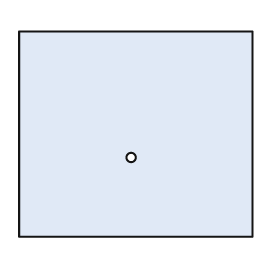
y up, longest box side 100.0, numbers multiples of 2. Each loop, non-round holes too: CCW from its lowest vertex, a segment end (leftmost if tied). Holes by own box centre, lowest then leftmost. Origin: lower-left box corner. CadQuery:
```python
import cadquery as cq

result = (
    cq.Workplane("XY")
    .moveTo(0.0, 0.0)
    .lineTo(100.0, 0.0)
    .lineTo(100.0, 88.0)
    .lineTo(0.0, 88.0)
    .close()
    .moveTo(48.0, 34.0)
    .circle(2.0)
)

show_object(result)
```